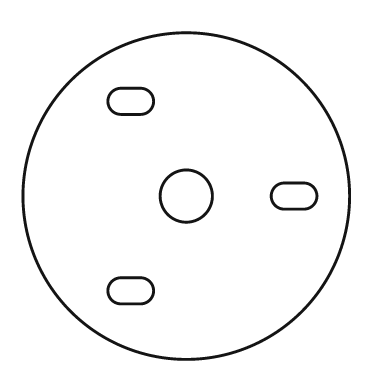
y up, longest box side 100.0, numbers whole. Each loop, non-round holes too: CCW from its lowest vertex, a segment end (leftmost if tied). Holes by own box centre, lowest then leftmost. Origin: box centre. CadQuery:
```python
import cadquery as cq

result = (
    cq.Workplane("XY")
    .moveTo(0.0, 0.0)
    .circle(50.0)
    .moveTo(-20.0, -33.0)
    .lineTo(-14.0, -33.0)
    .threePointArc((-10.0, -29.0), (-14.0, -25.0))
    .lineTo(-20.0, -25.0)
    .threePointArc((-24.0, -29.0), (-20.0, -33.0))
    .close()
    .moveTo(0.0, 0.0)
    .circle(8.0)
    .moveTo(30.0, -4.0)
    .lineTo(36.0, -4.0)
    .threePointArc((40.0, 0.0), (36.0, 4.0))
    .lineTo(30.0, 4.0)
    .threePointArc((26.0, 0.0), (30.0, -4.0))
    .close()
    .moveTo(-20.0, 25.0)
    .lineTo(-14.0, 25.0)
    .threePointArc((-10.0, 29.0), (-14.0, 33.0))
    .lineTo(-20.0, 33.0)
    .threePointArc((-24.0, 29.0), (-20.0, 25.0))
    .close()
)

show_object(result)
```